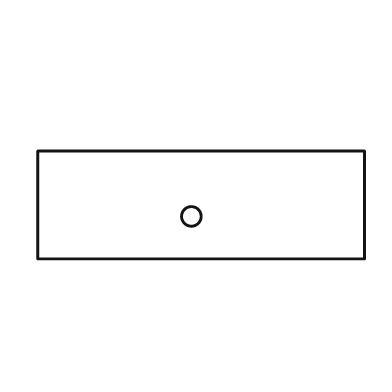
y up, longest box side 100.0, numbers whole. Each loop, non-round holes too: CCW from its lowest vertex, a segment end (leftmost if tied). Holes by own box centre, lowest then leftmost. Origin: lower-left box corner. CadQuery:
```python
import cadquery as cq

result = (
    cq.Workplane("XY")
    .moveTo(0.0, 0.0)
    .lineTo(100.0, 0.0)
    .lineTo(100.0, 33.0)
    .lineTo(0.0, 33.0)
    .close()
    .moveTo(47.0, 13.0)
    .circle(3.0)
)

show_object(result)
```